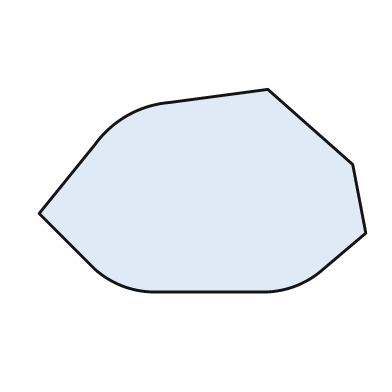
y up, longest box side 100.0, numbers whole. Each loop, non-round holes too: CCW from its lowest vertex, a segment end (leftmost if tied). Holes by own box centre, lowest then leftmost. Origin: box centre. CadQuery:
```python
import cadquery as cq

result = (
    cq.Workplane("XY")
    .moveTo(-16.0, -31.0)
    .lineTo(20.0, -31.0)
    .threePointArc((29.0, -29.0), (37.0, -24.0))
    .lineTo(50.0, -13.0)
    .lineTo(46.0, 8.0)
    .lineTo(20.0, 31.0)
    .lineTo(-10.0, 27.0)
    .threePointArc((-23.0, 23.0), (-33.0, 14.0))
    .lineTo(-50.0, -7.0)
    .lineTo(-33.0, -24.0)
    .threePointArc((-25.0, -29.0), (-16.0, -31.0))
    .close()
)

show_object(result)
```